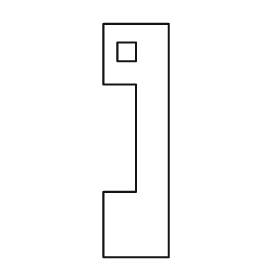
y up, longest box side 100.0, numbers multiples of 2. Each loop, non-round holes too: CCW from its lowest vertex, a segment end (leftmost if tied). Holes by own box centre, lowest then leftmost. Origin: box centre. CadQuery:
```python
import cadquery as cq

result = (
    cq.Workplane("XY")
    .moveTo(-14.0, -50.0)
    .lineTo(14.0, -50.0)
    .lineTo(14.0, 50.0)
    .lineTo(-14.0, 50.0)
    .lineTo(-14.0, 24.0)
    .lineTo(0.0, 24.0)
    .lineTo(0.0, -22.0)
    .lineTo(-14.0, -22.0)
    .close()
    .moveTo(-8.0, 34.0)
    .lineTo(0.0, 34.0)
    .lineTo(0.0, 42.0)
    .lineTo(-8.0, 42.0)
    .close()
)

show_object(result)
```